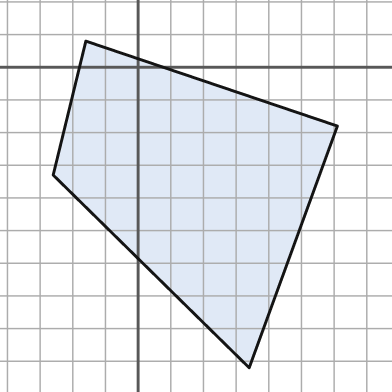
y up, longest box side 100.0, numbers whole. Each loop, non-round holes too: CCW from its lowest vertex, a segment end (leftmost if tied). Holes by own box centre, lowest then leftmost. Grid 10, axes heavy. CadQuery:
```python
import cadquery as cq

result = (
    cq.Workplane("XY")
    .moveTo(34.0, -92.0)
    .lineTo(61.0, -18.0)
    .lineTo(-16.0, 8.0)
    .lineTo(-26.0, -33.0)
    .close()
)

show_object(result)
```